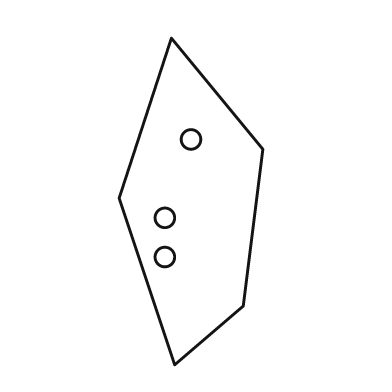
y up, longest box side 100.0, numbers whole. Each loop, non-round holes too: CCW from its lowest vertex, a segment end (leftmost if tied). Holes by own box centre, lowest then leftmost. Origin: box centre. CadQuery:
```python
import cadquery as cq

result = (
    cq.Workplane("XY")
    .moveTo(-5.0, -50.0)
    .lineTo(16.0, -32.0)
    .lineTo(22.0, 16.0)
    .lineTo(-6.0, 50.0)
    .lineTo(-22.0, 1.0)
    .close()
    .moveTo(-8.0, -17.0)
    .circle(3.0)
    .moveTo(-8.0, -5.0)
    .circle(3.0)
    .moveTo(0.0, 19.0)
    .circle(3.0)
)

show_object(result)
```